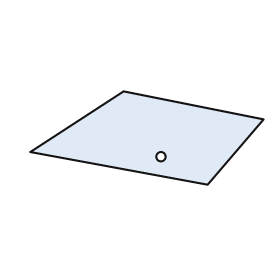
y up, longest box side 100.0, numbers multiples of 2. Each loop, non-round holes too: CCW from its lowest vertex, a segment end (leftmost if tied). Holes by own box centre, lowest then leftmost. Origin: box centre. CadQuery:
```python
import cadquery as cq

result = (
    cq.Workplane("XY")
    .moveTo(26.0, -20.0)
    .lineTo(50.0, 8.0)
    .lineTo(-10.0, 20.0)
    .lineTo(-50.0, -6.0)
    .close()
    .moveTo(6.0, -8.0)
    .circle(2.0)
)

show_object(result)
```